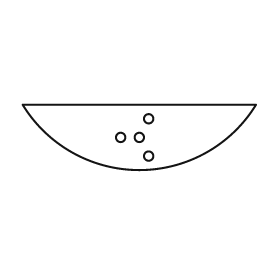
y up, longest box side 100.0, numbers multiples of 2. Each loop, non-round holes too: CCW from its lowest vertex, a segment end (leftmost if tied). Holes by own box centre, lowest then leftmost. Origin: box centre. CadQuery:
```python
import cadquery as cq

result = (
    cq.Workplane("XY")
    .moveTo(-50.0, 14.0)
    .threePointArc((0.0, -14.0), (50.0, 14.0))
    .close()
    .moveTo(4.0, -8.0)
    .circle(2.0)
    .moveTo(-8.0, 0.0)
    .circle(2.0)
    .moveTo(0.0, 0.0)
    .circle(2.0)
    .moveTo(4.0, 8.0)
    .circle(2.0)
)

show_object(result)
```